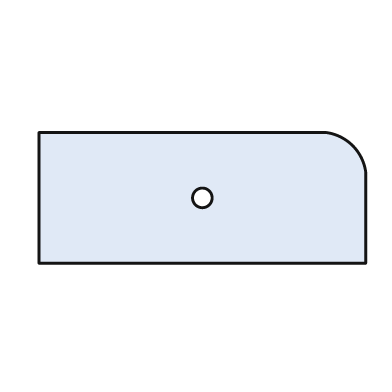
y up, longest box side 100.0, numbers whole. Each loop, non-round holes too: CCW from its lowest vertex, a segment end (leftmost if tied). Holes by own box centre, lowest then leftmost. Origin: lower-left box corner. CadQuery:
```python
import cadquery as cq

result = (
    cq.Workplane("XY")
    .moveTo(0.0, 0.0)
    .lineTo(100.0, 0.0)
    .lineTo(100.0, 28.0)
    .threePointArc((96.0, 36.0), (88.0, 40.0))
    .lineTo(0.0, 40.0)
    .close()
    .moveTo(50.0, 20.0)
    .circle(3.0)
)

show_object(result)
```